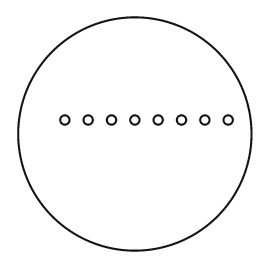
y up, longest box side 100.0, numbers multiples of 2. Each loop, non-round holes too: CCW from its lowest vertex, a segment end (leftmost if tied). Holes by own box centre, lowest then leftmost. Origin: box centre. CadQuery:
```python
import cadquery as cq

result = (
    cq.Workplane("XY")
    .moveTo(0.0, 0.0)
    .circle(50.0)
    .moveTo(-30.0, 6.0)
    .circle(2.0)
    .moveTo(-20.0, 6.0)
    .circle(2.0)
    .moveTo(-10.0, 6.0)
    .circle(2.0)
    .moveTo(0.0, 6.0)
    .circle(2.0)
    .moveTo(10.0, 6.0)
    .circle(2.0)
    .moveTo(20.0, 6.0)
    .circle(2.0)
    .moveTo(30.0, 6.0)
    .circle(2.0)
    .moveTo(40.0, 6.0)
    .circle(2.0)
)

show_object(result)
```